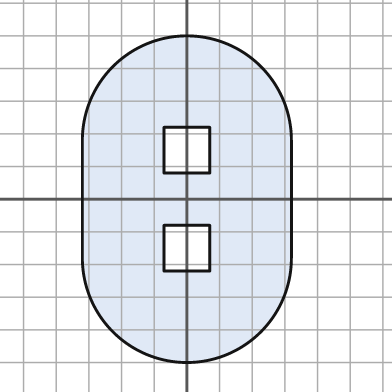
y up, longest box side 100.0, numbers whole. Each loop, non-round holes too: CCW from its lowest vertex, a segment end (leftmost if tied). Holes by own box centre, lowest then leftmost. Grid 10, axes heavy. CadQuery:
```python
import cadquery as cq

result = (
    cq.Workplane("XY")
    .moveTo(-32.0, -18.0)
    .threePointArc((0.0, -50.0), (32.0, -18.0))
    .lineTo(32.0, 18.0)
    .threePointArc((0.0, 50.0), (-32.0, 18.0))
    .close()
    .moveTo(-7.0, -22.0)
    .lineTo(7.0, -22.0)
    .lineTo(7.0, -8.0)
    .lineTo(-7.0, -8.0)
    .close()
    .moveTo(-7.0, 8.0)
    .lineTo(7.0, 8.0)
    .lineTo(7.0, 22.0)
    .lineTo(-7.0, 22.0)
    .close()
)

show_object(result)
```